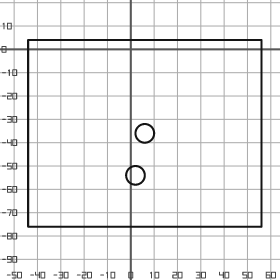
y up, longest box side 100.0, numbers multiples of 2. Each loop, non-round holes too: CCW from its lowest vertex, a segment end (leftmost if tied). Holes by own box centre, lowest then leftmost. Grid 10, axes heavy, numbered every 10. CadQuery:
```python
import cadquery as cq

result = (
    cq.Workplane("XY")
    .moveTo(-44.0, -76.0)
    .lineTo(56.0, -76.0)
    .lineTo(56.0, 4.0)
    .lineTo(-44.0, 4.0)
    .close()
    .moveTo(2.0, -54.0)
    .circle(4.0)
    .moveTo(6.0, -36.0)
    .circle(4.0)
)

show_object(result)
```